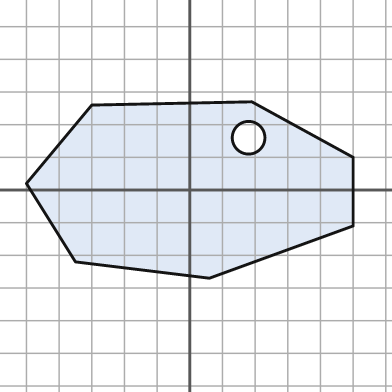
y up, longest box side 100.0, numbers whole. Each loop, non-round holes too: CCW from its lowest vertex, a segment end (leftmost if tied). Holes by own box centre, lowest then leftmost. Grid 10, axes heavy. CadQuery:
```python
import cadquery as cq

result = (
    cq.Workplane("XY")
    .moveTo(6.0, -27.0)
    .lineTo(50.0, -11.0)
    .lineTo(50.0, 10.0)
    .lineTo(19.0, 27.0)
    .lineTo(-30.0, 26.0)
    .lineTo(-50.0, 2.0)
    .lineTo(-35.0, -22.0)
    .close()
    .moveTo(18.0, 16.0)
    .circle(5.0)
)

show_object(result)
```